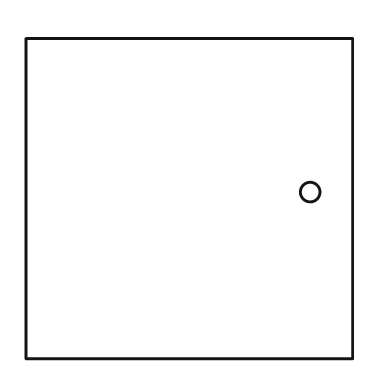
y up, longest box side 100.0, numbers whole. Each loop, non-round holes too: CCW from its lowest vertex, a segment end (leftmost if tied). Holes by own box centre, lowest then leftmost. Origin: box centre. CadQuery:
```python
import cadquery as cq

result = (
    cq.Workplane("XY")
    .moveTo(-50.0, -49.0)
    .lineTo(50.0, -49.0)
    .lineTo(50.0, 49.0)
    .lineTo(-50.0, 49.0)
    .close()
    .moveTo(37.0, 2.0)
    .circle(3.0)
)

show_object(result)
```